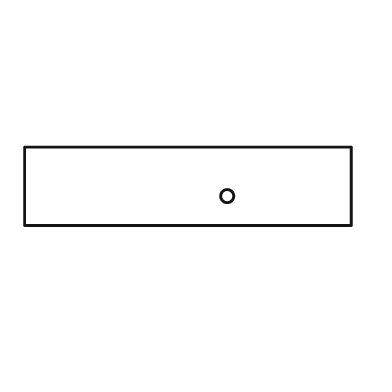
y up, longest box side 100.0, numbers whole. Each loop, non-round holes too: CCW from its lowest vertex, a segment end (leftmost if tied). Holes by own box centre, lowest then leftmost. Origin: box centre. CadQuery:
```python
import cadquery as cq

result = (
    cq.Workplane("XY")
    .moveTo(-50.0, -12.0)
    .lineTo(50.0, -12.0)
    .lineTo(50.0, 12.0)
    .lineTo(-50.0, 12.0)
    .close()
    .moveTo(12.0, -3.0)
    .circle(2.0)
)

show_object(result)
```